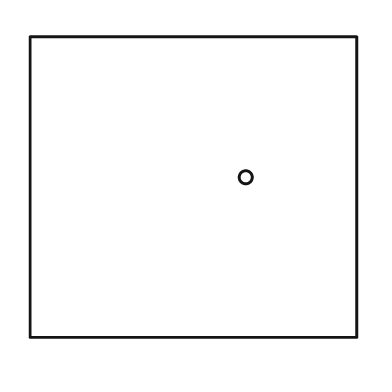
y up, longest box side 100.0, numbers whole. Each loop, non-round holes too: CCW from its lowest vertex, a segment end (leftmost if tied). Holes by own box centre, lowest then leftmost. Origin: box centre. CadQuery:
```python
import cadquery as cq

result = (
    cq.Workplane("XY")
    .moveTo(-50.0, -46.0)
    .lineTo(50.0, -46.0)
    .lineTo(50.0, 46.0)
    .lineTo(-50.0, 46.0)
    .close()
    .moveTo(16.0, 3.0)
    .circle(2.0)
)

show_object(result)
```